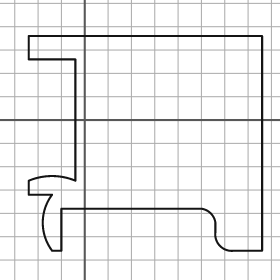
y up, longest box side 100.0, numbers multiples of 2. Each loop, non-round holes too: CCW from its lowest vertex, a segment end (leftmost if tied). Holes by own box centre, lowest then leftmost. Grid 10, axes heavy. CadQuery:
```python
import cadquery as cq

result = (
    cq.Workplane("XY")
    .moveTo(-14.0, -56.0)
    .lineTo(-10.0, -56.0)
    .lineTo(-10.0, -38.0)
    .lineTo(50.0, -38.0)
    .threePointArc((54.0, -40.0), (56.0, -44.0))
    .lineTo(56.0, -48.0)
    .threePointArc((58.0, -54.0), (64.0, -56.0))
    .lineTo(76.0, -56.0)
    .lineTo(76.0, 36.0)
    .lineTo(-24.0, 36.0)
    .lineTo(-24.0, 26.0)
    .lineTo(-4.0, 26.0)
    .lineTo(-4.0, -26.0)
    .threePointArc((-14.0, -24.0), (-24.0, -26.0))
    .lineTo(-24.0, -32.0)
    .lineTo(-14.0, -32.0)
    .threePointArc((-18.0, -44.0), (-14.0, -56.0))
    .close()
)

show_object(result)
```